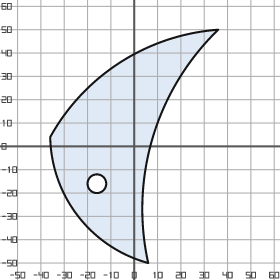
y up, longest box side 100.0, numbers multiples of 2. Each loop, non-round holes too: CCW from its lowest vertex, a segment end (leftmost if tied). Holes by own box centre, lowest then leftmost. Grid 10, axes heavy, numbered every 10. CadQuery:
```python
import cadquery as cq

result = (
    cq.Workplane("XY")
    .moveTo(6.0, -50.0)
    .threePointArc((8.0, 4.0), (36.0, 50.0))
    .threePointArc((-6.0, 36.0), (-36.0, 4.0))
    .threePointArc((-24.0, -30.0), (6.0, -50.0))
    .close()
    .moveTo(-16.0, -16.0)
    .circle(4.0)
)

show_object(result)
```